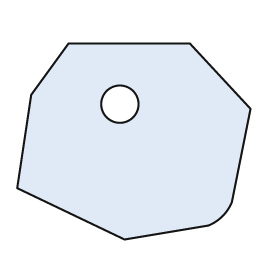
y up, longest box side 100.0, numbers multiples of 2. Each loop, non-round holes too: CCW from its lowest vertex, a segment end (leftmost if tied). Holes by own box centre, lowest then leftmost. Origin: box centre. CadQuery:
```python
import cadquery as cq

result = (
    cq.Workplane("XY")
    .moveTo(-4.0, -42.0)
    .lineTo(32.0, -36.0)
    .threePointArc((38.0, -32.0), (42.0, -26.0))
    .lineTo(50.0, 14.0)
    .lineTo(24.0, 42.0)
    .lineTo(-28.0, 42.0)
    .lineTo(-44.0, 20.0)
    .lineTo(-50.0, -20.0)
    .close()
    .moveTo(-6.0, 16.0)
    .circle(8.0)
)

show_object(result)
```